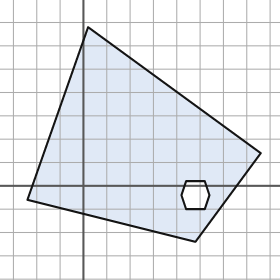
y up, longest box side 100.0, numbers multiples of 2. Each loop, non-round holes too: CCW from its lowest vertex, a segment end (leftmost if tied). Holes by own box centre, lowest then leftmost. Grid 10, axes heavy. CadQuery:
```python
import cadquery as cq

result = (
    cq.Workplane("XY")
    .moveTo(48.0, -24.0)
    .lineTo(76.0, 14.0)
    .lineTo(2.0, 68.0)
    .lineTo(-24.0, -6.0)
    .close()
    .moveTo(44.0, -10.0)
    .lineTo(52.0, -10.0)
    .lineTo(54.0, -4.0)
    .lineTo(52.0, 2.0)
    .lineTo(44.0, 2.0)
    .lineTo(42.0, -4.0)
    .close()
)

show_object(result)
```